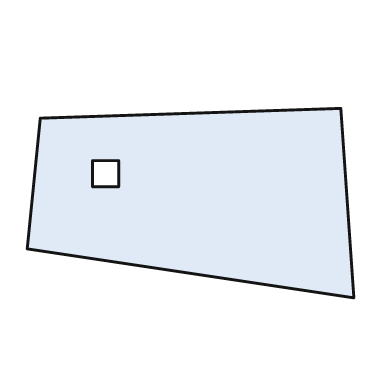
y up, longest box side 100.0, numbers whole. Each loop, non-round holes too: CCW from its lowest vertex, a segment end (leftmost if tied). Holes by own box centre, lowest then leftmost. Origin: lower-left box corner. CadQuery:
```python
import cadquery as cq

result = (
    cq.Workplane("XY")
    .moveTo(100.0, 0.0)
    .lineTo(96.0, 58.0)
    .lineTo(4.0, 55.0)
    .lineTo(0.0, 15.0)
    .close()
    .moveTo(20.0, 34.0)
    .lineTo(28.0, 34.0)
    .lineTo(28.0, 42.0)
    .lineTo(20.0, 42.0)
    .close()
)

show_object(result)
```